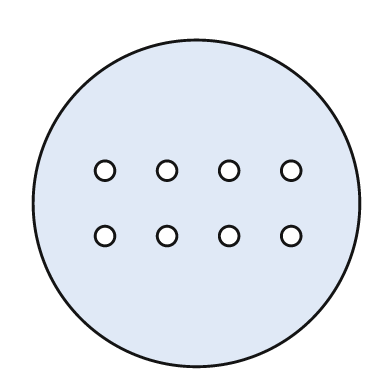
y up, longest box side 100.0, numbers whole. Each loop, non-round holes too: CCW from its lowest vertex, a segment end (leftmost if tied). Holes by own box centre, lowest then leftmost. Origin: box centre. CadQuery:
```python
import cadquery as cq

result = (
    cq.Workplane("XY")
    .moveTo(0.0, 0.0)
    .circle(50.0)
    .moveTo(-28.0, -10.0)
    .circle(3.0)
    .moveTo(-9.0, -10.0)
    .circle(3.0)
    .moveTo(10.0, -10.0)
    .circle(3.0)
    .moveTo(29.0, -10.0)
    .circle(3.0)
    .moveTo(-28.0, 10.0)
    .circle(3.0)
    .moveTo(-9.0, 10.0)
    .circle(3.0)
    .moveTo(10.0, 10.0)
    .circle(3.0)
    .moveTo(29.0, 10.0)
    .circle(3.0)
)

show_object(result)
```